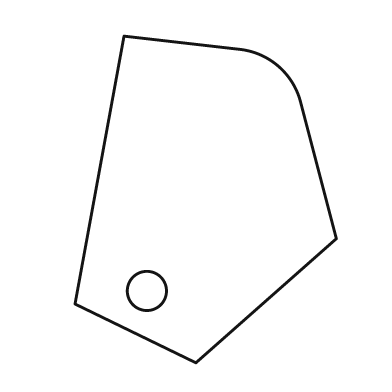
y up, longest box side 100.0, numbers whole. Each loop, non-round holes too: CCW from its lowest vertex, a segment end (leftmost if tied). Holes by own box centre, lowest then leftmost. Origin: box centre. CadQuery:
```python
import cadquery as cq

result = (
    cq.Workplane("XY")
    .moveTo(-3.0, -50.0)
    .lineTo(40.0, -12.0)
    .lineTo(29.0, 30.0)
    .threePointArc((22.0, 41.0), (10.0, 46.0))
    .lineTo(-25.0, 50.0)
    .lineTo(-40.0, -32.0)
    .close()
    .moveTo(-18.0, -28.0)
    .circle(6.0)
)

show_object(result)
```